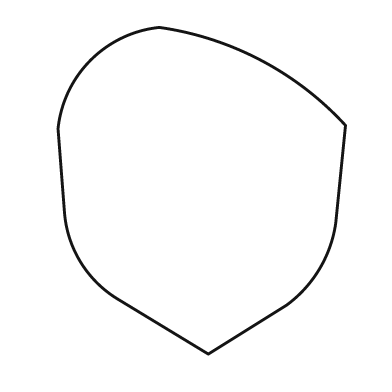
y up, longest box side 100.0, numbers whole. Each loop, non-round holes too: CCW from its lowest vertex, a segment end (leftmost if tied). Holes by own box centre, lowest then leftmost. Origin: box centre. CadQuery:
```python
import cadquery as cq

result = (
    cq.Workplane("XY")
    .moveTo(2.0, -50.0)
    .lineTo(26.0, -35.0)
    .threePointArc((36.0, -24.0), (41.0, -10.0))
    .lineTo(44.0, 20.0)
    .threePointArc((18.0, 40.0), (-13.0, 50.0))
    .threePointArc((-34.0, 40.0), (-44.0, 19.0))
    .lineTo(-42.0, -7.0)
    .threePointArc((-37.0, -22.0), (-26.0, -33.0))
    .close()
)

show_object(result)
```